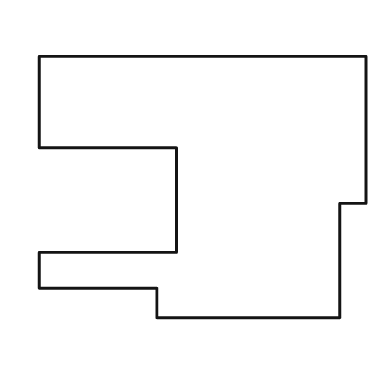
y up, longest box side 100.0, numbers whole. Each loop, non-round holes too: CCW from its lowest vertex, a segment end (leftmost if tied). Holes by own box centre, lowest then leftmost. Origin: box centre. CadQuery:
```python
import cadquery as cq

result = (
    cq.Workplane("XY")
    .moveTo(-14.0, -40.0)
    .lineTo(42.0, -40.0)
    .lineTo(42.0, -5.0)
    .lineTo(50.0, -5.0)
    .lineTo(50.0, 40.0)
    .lineTo(-50.0, 40.0)
    .lineTo(-50.0, 12.0)
    .lineTo(-8.0, 12.0)
    .lineTo(-8.0, -20.0)
    .lineTo(-50.0, -20.0)
    .lineTo(-50.0, -31.0)
    .lineTo(-14.0, -31.0)
    .close()
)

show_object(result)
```